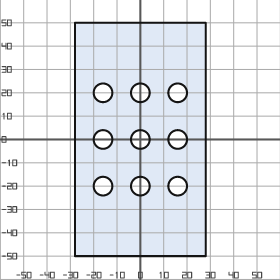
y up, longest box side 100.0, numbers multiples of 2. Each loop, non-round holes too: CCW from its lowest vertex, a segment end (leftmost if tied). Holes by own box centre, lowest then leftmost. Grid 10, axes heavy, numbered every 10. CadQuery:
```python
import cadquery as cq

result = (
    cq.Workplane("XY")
    .moveTo(-28.0, -50.0)
    .lineTo(28.0, -50.0)
    .lineTo(28.0, 50.0)
    .lineTo(-28.0, 50.0)
    .close()
    .moveTo(-16.0, -20.0)
    .circle(4.0)
    .moveTo(0.0, -20.0)
    .circle(4.0)
    .moveTo(16.0, -20.0)
    .circle(4.0)
    .moveTo(-16.0, 0.0)
    .circle(4.0)
    .moveTo(0.0, 0.0)
    .circle(4.0)
    .moveTo(16.0, 0.0)
    .circle(4.0)
    .moveTo(-16.0, 20.0)
    .circle(4.0)
    .moveTo(0.0, 20.0)
    .circle(4.0)
    .moveTo(16.0, 20.0)
    .circle(4.0)
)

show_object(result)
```